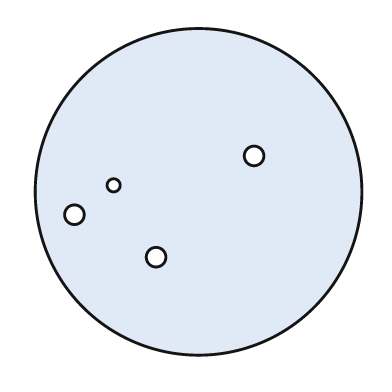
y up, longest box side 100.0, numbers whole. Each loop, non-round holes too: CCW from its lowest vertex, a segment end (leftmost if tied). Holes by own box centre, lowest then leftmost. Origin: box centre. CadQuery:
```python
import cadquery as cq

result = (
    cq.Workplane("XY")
    .moveTo(0.0, 0.0)
    .circle(50.0)
    .moveTo(-13.0, -20.0)
    .circle(3.0)
    .moveTo(-38.0, -7.0)
    .circle(3.0)
    .moveTo(-26.0, 2.0)
    .circle(2.0)
    .moveTo(17.0, 11.0)
    .circle(3.0)
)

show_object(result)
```